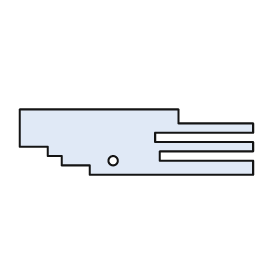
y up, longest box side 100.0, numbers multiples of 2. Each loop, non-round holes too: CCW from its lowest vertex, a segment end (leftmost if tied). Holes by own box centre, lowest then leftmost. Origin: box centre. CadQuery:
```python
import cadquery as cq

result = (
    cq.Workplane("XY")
    .moveTo(-20.0, -14.0)
    .lineTo(50.0, -14.0)
    .lineTo(50.0, -8.0)
    .lineTo(10.0, -8.0)
    .lineTo(10.0, -4.0)
    .lineTo(50.0, -4.0)
    .lineTo(50.0, 0.0)
    .lineTo(8.0, 0.0)
    .lineTo(8.0, 4.0)
    .lineTo(50.0, 4.0)
    .lineTo(50.0, 8.0)
    .lineTo(18.0, 8.0)
    .lineTo(18.0, 14.0)
    .lineTo(-50.0, 14.0)
    .lineTo(-50.0, -2.0)
    .lineTo(-38.0, -2.0)
    .lineTo(-38.0, -6.0)
    .lineTo(-32.0, -6.0)
    .lineTo(-32.0, -10.0)
    .lineTo(-20.0, -10.0)
    .close()
    .moveTo(-10.0, -8.0)
    .circle(2.0)
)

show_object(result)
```